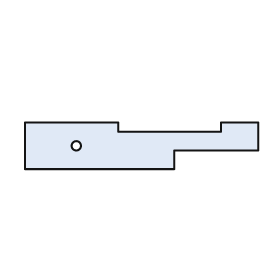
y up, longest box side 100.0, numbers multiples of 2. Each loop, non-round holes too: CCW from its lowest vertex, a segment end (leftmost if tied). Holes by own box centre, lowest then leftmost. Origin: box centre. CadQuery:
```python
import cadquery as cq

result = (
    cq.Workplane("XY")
    .moveTo(-50.0, -10.0)
    .lineTo(14.0, -10.0)
    .lineTo(14.0, -2.0)
    .lineTo(50.0, -2.0)
    .lineTo(50.0, 10.0)
    .lineTo(34.0, 10.0)
    .lineTo(34.0, 6.0)
    .lineTo(-10.0, 6.0)
    .lineTo(-10.0, 10.0)
    .lineTo(-50.0, 10.0)
    .close()
    .moveTo(-28.0, 0.0)
    .circle(2.0)
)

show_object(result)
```